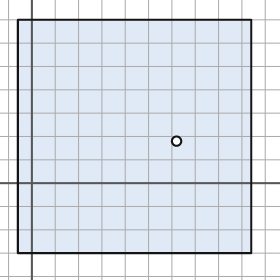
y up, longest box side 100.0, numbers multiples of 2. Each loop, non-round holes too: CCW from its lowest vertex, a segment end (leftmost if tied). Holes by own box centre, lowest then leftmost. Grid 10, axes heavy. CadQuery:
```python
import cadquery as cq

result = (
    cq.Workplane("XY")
    .moveTo(-6.0, -30.0)
    .lineTo(94.0, -30.0)
    .lineTo(94.0, 70.0)
    .lineTo(-6.0, 70.0)
    .close()
    .moveTo(62.0, 18.0)
    .circle(2.0)
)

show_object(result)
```